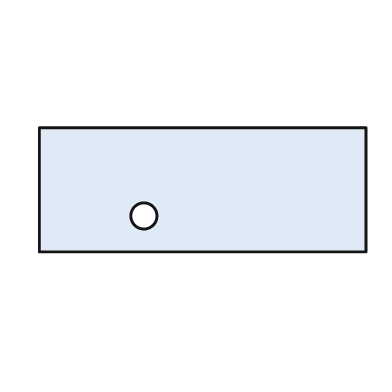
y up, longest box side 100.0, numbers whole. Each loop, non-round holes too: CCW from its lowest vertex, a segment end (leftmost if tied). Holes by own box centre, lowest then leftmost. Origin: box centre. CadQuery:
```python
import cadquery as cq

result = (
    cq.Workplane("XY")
    .moveTo(-50.0, -19.0)
    .lineTo(50.0, -19.0)
    .lineTo(50.0, 19.0)
    .lineTo(-50.0, 19.0)
    .close()
    .moveTo(-18.0, -8.0)
    .circle(4.0)
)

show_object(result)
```